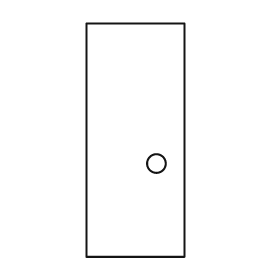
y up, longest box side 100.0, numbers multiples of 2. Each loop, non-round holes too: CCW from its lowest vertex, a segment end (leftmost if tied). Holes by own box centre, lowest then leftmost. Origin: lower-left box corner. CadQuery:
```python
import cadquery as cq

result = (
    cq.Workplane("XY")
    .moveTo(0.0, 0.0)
    .lineTo(42.0, 0.0)
    .lineTo(42.0, 100.0)
    .lineTo(0.0, 100.0)
    .close()
    .moveTo(30.0, 40.0)
    .circle(4.0)
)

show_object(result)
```